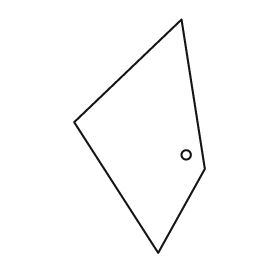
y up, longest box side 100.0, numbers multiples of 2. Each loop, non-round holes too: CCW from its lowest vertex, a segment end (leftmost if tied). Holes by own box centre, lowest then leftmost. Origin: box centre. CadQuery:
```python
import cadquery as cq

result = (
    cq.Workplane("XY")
    .moveTo(8.0, -50.0)
    .lineTo(28.0, -14.0)
    .lineTo(18.0, 50.0)
    .lineTo(-28.0, 6.0)
    .close()
    .moveTo(20.0, -8.0)
    .circle(2.0)
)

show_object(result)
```